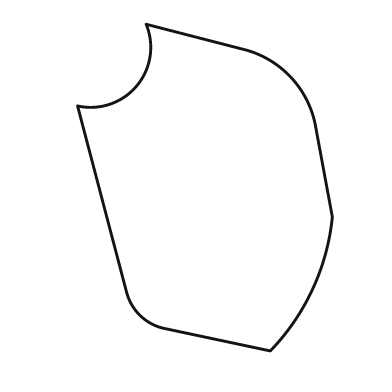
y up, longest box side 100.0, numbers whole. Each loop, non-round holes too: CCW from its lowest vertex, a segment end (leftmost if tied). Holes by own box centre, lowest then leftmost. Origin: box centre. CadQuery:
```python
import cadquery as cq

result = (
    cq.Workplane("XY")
    .moveTo(20.0, -50.0)
    .threePointArc((33.0, -31.0), (39.0, -9.0))
    .lineTo(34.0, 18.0)
    .threePointArc((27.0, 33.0), (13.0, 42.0))
    .lineTo(-18.0, 50.0)
    .threePointArc((-21.0, 31.0), (-39.0, 25.0))
    .lineTo(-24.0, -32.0)
    .threePointArc((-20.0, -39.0), (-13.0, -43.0))
    .close()
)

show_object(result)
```